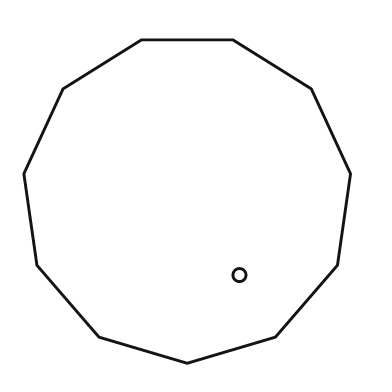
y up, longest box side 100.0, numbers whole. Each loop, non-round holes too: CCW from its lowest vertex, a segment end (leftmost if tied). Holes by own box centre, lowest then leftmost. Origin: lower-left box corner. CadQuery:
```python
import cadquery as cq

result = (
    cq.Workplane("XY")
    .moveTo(50.0, 0.0)
    .lineTo(77.0, 8.0)
    .lineTo(96.0, 30.0)
    .lineTo(100.0, 58.0)
    .lineTo(88.0, 84.0)
    .lineTo(64.0, 99.0)
    .lineTo(36.0, 99.0)
    .lineTo(12.0, 84.0)
    .lineTo(0.0, 58.0)
    .lineTo(4.0, 30.0)
    .lineTo(23.0, 8.0)
    .close()
    .moveTo(66.0, 27.0)
    .circle(2.0)
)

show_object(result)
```